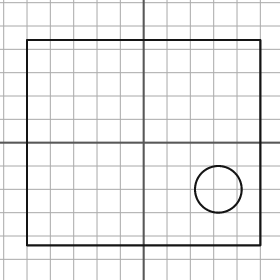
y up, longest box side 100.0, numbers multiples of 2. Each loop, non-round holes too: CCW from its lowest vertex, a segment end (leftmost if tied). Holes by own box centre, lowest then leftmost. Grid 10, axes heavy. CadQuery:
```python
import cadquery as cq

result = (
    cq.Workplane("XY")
    .moveTo(-50.0, -44.0)
    .lineTo(50.0, -44.0)
    .lineTo(50.0, 44.0)
    .lineTo(-50.0, 44.0)
    .close()
    .moveTo(32.0, -20.0)
    .circle(10.0)
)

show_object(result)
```